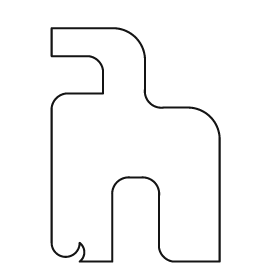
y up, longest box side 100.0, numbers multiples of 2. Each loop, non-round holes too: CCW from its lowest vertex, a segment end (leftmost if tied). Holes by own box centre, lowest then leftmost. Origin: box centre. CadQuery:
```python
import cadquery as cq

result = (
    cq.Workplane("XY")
    .moveTo(-24.0, -50.0)
    .lineTo(-10.0, -50.0)
    .lineTo(-10.0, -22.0)
    .threePointArc((-8.0, -16.0), (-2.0, -14.0))
    .lineTo(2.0, -14.0)
    .threePointArc((8.0, -16.0), (10.0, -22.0))
    .lineTo(10.0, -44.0)
    .threePointArc((12.0, -48.0), (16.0, -50.0))
    .lineTo(36.0, -50.0)
    .lineTo(36.0, 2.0)
    .threePointArc((32.0, 12.0), (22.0, 16.0))
    .lineTo(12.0, 16.0)
    .threePointArc((6.0, 18.0), (4.0, 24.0))
    .lineTo(4.0, 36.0)
    .threePointArc((0.0, 46.0), (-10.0, 50.0))
    .lineTo(-36.0, 50.0)
    .lineTo(-36.0, 38.0)
    .lineTo(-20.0, 38.0)
    .threePointArc((-16.0, 36.0), (-14.0, 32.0))
    .lineTo(-14.0, 22.0)
    .lineTo(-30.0, 22.0)
    .threePointArc((-34.0, 20.0), (-36.0, 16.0))
    .lineTo(-36.0, -42.0)
    .threePointArc((-30.0, -48.0), (-24.0, -42.0))
    .threePointArc((-22.0, -46.0), (-24.0, -50.0))
    .close()
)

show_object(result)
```